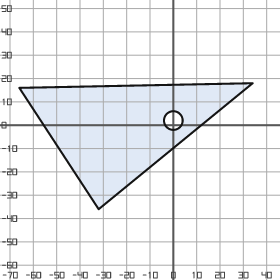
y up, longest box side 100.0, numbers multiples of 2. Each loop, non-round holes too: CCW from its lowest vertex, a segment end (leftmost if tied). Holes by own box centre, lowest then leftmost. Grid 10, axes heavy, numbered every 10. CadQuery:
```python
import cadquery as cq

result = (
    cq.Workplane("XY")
    .moveTo(-32.0, -36.0)
    .lineTo(34.0, 18.0)
    .lineTo(-66.0, 16.0)
    .close()
    .moveTo(0.0, 2.0)
    .circle(4.0)
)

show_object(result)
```